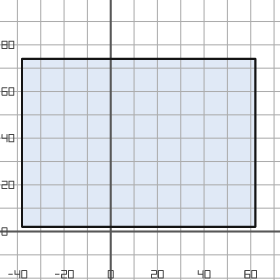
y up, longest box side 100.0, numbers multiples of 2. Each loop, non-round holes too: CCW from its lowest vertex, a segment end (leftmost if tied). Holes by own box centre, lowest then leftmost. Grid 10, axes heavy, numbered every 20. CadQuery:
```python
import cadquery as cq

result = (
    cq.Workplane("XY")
    .moveTo(-38.0, 2.0)
    .lineTo(62.0, 2.0)
    .lineTo(62.0, 74.0)
    .lineTo(-38.0, 74.0)
    .close()
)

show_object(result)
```